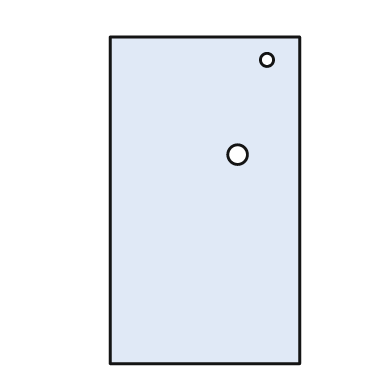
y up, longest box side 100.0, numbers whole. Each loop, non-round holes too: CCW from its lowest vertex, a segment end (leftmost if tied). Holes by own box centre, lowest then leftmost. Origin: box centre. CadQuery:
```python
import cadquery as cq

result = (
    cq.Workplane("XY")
    .moveTo(-29.0, -50.0)
    .lineTo(29.0, -50.0)
    .lineTo(29.0, 50.0)
    .lineTo(-29.0, 50.0)
    .close()
    .moveTo(10.0, 14.0)
    .circle(3.0)
    .moveTo(19.0, 43.0)
    .circle(2.0)
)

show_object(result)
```